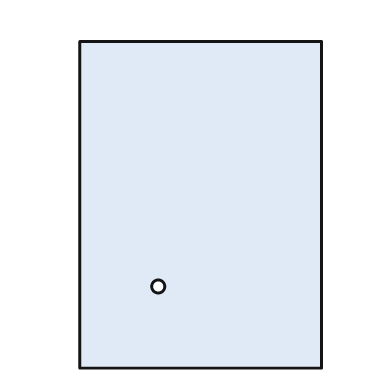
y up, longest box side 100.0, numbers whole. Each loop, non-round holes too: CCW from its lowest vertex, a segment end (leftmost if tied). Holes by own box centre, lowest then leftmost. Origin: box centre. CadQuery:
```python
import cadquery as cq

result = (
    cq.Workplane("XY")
    .moveTo(-37.0, -50.0)
    .lineTo(37.0, -50.0)
    .lineTo(37.0, 50.0)
    .lineTo(-37.0, 50.0)
    .close()
    .moveTo(-13.0, -25.0)
    .circle(2.0)
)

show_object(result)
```